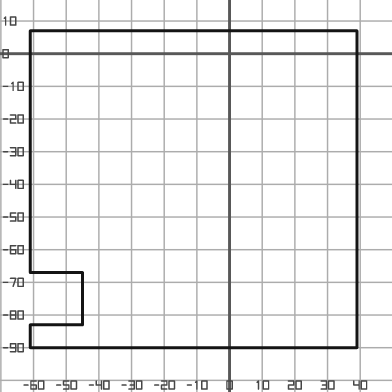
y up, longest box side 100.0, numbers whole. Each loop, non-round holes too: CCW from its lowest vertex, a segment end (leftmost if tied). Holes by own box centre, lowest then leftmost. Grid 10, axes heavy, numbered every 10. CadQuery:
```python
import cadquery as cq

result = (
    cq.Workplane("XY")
    .moveTo(-61.0, -90.0)
    .lineTo(39.0, -90.0)
    .lineTo(39.0, 7.0)
    .lineTo(-61.0, 7.0)
    .lineTo(-61.0, -67.0)
    .lineTo(-45.0, -67.0)
    .lineTo(-45.0, -83.0)
    .lineTo(-61.0, -83.0)
    .close()
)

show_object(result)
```